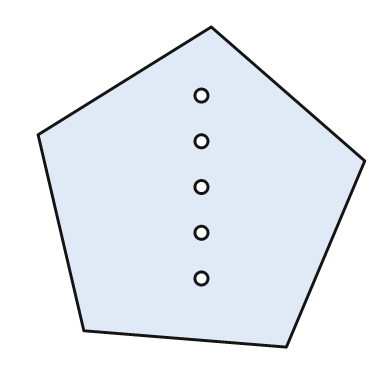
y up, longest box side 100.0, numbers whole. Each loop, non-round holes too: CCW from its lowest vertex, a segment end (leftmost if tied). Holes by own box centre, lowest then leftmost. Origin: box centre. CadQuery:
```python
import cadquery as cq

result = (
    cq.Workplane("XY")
    .moveTo(26.0, -49.0)
    .lineTo(50.0, 8.0)
    .lineTo(3.0, 49.0)
    .lineTo(-50.0, 16.0)
    .lineTo(-36.0, -44.0)
    .close()
    .moveTo(0.0, -28.0)
    .circle(2.0)
    .moveTo(0.0, -14.0)
    .circle(2.0)
    .moveTo(0.0, 0.0)
    .circle(2.0)
    .moveTo(0.0, 14.0)
    .circle(2.0)
    .moveTo(0.0, 28.0)
    .circle(2.0)
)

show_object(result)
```